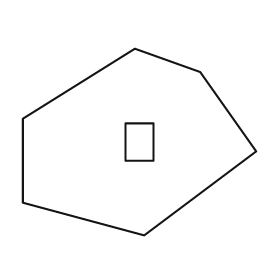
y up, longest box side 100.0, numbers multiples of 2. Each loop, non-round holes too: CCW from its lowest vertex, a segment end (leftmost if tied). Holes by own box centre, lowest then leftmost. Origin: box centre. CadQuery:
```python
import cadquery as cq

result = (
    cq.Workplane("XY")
    .moveTo(2.0, -40.0)
    .lineTo(50.0, -4.0)
    .lineTo(26.0, 30.0)
    .lineTo(-2.0, 40.0)
    .lineTo(-50.0, 10.0)
    .lineTo(-50.0, -26.0)
    .close()
    .moveTo(-6.0, -8.0)
    .lineTo(6.0, -8.0)
    .lineTo(6.0, 8.0)
    .lineTo(-6.0, 8.0)
    .close()
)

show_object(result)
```